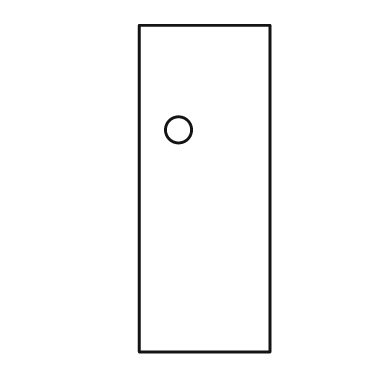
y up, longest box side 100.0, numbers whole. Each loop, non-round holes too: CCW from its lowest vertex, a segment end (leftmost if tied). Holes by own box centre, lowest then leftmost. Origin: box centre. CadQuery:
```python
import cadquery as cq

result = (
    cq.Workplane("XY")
    .moveTo(-20.0, -50.0)
    .lineTo(20.0, -50.0)
    .lineTo(20.0, 50.0)
    .lineTo(-20.0, 50.0)
    .close()
    .moveTo(-8.0, 18.0)
    .circle(4.0)
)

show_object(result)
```